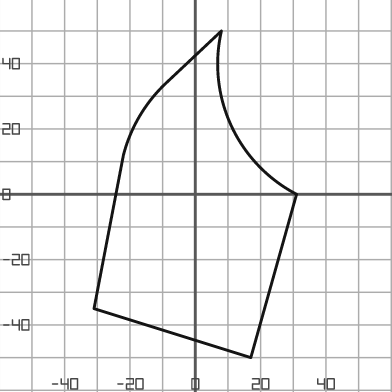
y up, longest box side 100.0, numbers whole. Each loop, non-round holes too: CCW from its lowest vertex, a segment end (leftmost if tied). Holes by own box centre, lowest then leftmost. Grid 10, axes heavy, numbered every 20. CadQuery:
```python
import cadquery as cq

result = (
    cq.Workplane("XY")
    .moveTo(17.0, -50.0)
    .lineTo(31.0, 0.0)
    .threePointArc((11.0, 21.0), (8.0, 50.0))
    .lineTo(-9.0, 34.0)
    .threePointArc((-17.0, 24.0), (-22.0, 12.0))
    .lineTo(-31.0, -35.0)
    .close()
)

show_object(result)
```